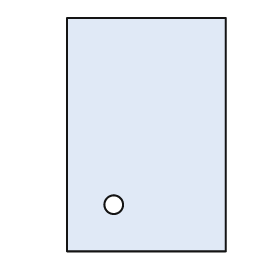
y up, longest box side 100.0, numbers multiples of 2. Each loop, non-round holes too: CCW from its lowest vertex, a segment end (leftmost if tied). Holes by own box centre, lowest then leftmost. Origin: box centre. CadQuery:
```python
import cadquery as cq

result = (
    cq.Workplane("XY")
    .moveTo(-34.0, -50.0)
    .lineTo(34.0, -50.0)
    .lineTo(34.0, 50.0)
    .lineTo(-34.0, 50.0)
    .close()
    .moveTo(-14.0, -30.0)
    .circle(4.0)
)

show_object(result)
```